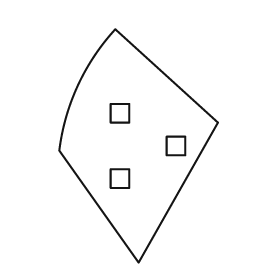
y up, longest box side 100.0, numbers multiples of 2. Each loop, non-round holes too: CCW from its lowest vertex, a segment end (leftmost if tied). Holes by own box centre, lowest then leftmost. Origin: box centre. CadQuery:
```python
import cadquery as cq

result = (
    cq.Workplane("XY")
    .moveTo(0.0, -50.0)
    .lineTo(34.0, 10.0)
    .lineTo(-10.0, 50.0)
    .threePointArc((-26.0, 26.0), (-34.0, -2.0))
    .close()
    .moveTo(-12.0, -18.0)
    .lineTo(-4.0, -18.0)
    .lineTo(-4.0, -10.0)
    .lineTo(-12.0, -10.0)
    .close()
    .moveTo(12.0, -4.0)
    .lineTo(20.0, -4.0)
    .lineTo(20.0, 4.0)
    .lineTo(12.0, 4.0)
    .close()
    .moveTo(-12.0, 10.0)
    .lineTo(-4.0, 10.0)
    .lineTo(-4.0, 18.0)
    .lineTo(-12.0, 18.0)
    .close()
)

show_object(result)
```